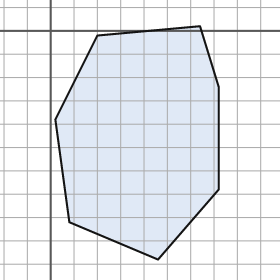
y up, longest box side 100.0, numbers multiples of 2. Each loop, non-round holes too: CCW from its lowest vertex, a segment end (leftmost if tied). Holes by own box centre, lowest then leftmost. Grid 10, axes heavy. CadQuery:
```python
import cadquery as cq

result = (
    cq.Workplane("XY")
    .moveTo(46.0, -98.0)
    .lineTo(72.0, -68.0)
    .lineTo(72.0, -24.0)
    .lineTo(64.0, 2.0)
    .lineTo(20.0, -2.0)
    .lineTo(2.0, -38.0)
    .lineTo(8.0, -82.0)
    .close()
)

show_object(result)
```